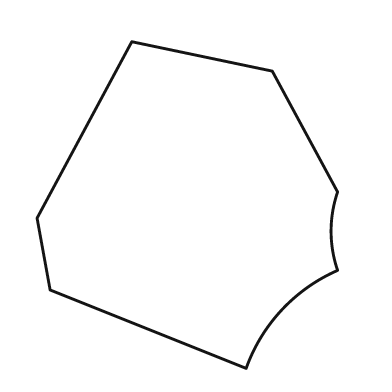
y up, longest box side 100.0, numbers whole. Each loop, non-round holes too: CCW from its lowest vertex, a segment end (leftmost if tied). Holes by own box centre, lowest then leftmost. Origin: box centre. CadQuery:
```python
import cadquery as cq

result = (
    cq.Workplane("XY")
    .moveTo(18.0, -50.0)
    .threePointArc((29.0, -32.0), (46.0, -20.0))
    .threePointArc((44.0, -8.0), (46.0, 4.0))
    .lineTo(26.0, 41.0)
    .lineTo(-17.0, 50.0)
    .lineTo(-46.0, -4.0)
    .lineTo(-42.0, -26.0)
    .close()
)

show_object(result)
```